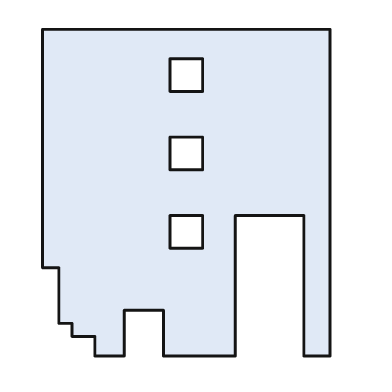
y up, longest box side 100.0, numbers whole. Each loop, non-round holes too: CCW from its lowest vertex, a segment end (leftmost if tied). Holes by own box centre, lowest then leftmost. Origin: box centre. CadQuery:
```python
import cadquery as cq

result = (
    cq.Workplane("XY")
    .moveTo(-28.0, -50.0)
    .lineTo(-19.0, -50.0)
    .lineTo(-19.0, -36.0)
    .lineTo(-7.0, -36.0)
    .lineTo(-7.0, -50.0)
    .lineTo(15.0, -50.0)
    .lineTo(15.0, -7.0)
    .lineTo(36.0, -7.0)
    .lineTo(36.0, -50.0)
    .lineTo(44.0, -50.0)
    .lineTo(44.0, 50.0)
    .lineTo(-44.0, 50.0)
    .lineTo(-44.0, -23.0)
    .lineTo(-39.0, -23.0)
    .lineTo(-39.0, -40.0)
    .lineTo(-35.0, -40.0)
    .lineTo(-35.0, -44.0)
    .lineTo(-28.0, -44.0)
    .close()
    .moveTo(-5.0, -17.0)
    .lineTo(5.0, -17.0)
    .lineTo(5.0, -7.0)
    .lineTo(-5.0, -7.0)
    .close()
    .moveTo(-5.0, 7.0)
    .lineTo(5.0, 7.0)
    .lineTo(5.0, 17.0)
    .lineTo(-5.0, 17.0)
    .close()
    .moveTo(-5.0, 31.0)
    .lineTo(5.0, 31.0)
    .lineTo(5.0, 41.0)
    .lineTo(-5.0, 41.0)
    .close()
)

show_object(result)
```